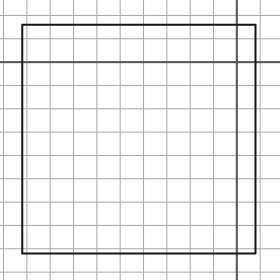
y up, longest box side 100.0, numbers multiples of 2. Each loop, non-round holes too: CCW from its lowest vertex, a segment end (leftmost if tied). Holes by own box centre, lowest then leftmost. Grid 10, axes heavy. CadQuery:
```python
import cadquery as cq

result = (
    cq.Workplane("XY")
    .moveTo(-92.0, -82.0)
    .lineTo(8.0, -82.0)
    .lineTo(8.0, 16.0)
    .lineTo(-92.0, 16.0)
    .close()
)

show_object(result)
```